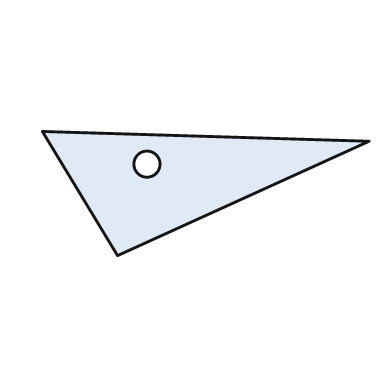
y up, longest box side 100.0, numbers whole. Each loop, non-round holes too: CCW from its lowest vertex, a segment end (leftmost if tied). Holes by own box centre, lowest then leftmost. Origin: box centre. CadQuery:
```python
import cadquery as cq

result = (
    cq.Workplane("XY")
    .moveTo(-27.0, -19.0)
    .lineTo(50.0, 16.0)
    .lineTo(-50.0, 19.0)
    .close()
    .moveTo(-18.0, 9.0)
    .circle(4.0)
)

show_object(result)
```